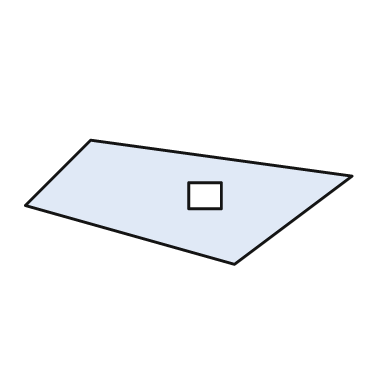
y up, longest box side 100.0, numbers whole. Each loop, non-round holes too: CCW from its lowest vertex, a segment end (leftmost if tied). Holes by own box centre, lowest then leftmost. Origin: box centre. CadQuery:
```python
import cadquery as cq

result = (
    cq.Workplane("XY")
    .moveTo(14.0, -19.0)
    .lineTo(50.0, 8.0)
    .lineTo(-30.0, 19.0)
    .lineTo(-50.0, -1.0)
    .close()
    .moveTo(0.0, -2.0)
    .lineTo(10.0, -2.0)
    .lineTo(10.0, 6.0)
    .lineTo(0.0, 6.0)
    .close()
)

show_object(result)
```